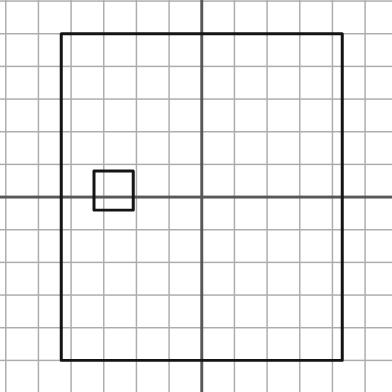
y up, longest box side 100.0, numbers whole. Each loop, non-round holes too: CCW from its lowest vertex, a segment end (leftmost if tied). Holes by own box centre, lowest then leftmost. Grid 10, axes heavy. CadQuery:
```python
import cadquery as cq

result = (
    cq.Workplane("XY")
    .moveTo(-43.0, -50.0)
    .lineTo(43.0, -50.0)
    .lineTo(43.0, 50.0)
    .lineTo(-43.0, 50.0)
    .close()
    .moveTo(-33.0, -4.0)
    .lineTo(-21.0, -4.0)
    .lineTo(-21.0, 8.0)
    .lineTo(-33.0, 8.0)
    .close()
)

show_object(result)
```